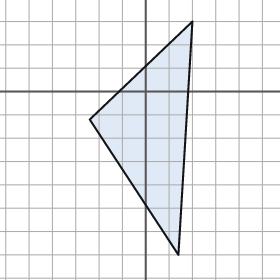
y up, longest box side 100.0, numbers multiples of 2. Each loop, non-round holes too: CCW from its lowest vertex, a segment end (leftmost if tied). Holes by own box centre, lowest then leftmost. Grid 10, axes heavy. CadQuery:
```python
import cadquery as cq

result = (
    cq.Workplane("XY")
    .moveTo(14.0, -70.0)
    .lineTo(20.0, 30.0)
    .lineTo(-24.0, -12.0)
    .close()
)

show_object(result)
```